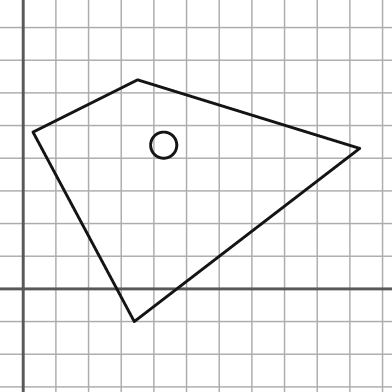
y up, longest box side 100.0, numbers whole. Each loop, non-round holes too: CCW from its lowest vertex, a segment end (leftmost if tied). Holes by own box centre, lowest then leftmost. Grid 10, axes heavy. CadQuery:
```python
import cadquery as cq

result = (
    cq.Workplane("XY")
    .moveTo(34.0, -10.0)
    .lineTo(103.0, 43.0)
    .lineTo(35.0, 64.0)
    .lineTo(3.0, 48.0)
    .close()
    .moveTo(43.0, 44.0)
    .circle(4.0)
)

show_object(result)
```